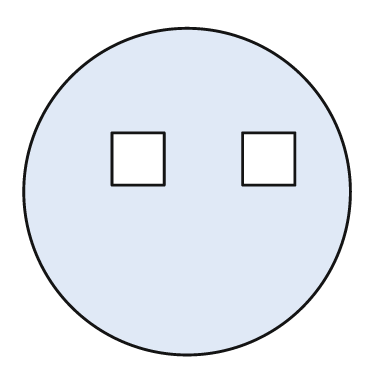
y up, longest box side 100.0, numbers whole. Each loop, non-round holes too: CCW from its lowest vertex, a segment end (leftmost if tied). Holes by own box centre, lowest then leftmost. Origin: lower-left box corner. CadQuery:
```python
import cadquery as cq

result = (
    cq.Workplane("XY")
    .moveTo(50.0, 50.0)
    .circle(50.0)
    .moveTo(27.0, 52.0)
    .lineTo(43.0, 52.0)
    .lineTo(43.0, 68.0)
    .lineTo(27.0, 68.0)
    .close()
    .moveTo(67.0, 52.0)
    .lineTo(83.0, 52.0)
    .lineTo(83.0, 68.0)
    .lineTo(67.0, 68.0)
    .close()
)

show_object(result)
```